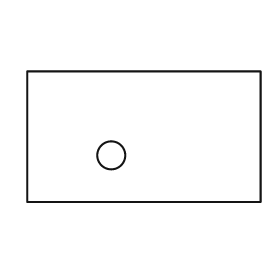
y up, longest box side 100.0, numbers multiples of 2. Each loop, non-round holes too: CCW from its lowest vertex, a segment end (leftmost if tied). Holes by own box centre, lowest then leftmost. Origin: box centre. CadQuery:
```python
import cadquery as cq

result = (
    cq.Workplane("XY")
    .moveTo(-50.0, -28.0)
    .lineTo(50.0, -28.0)
    .lineTo(50.0, 28.0)
    .lineTo(-50.0, 28.0)
    .close()
    .moveTo(-14.0, -8.0)
    .circle(6.0)
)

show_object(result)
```